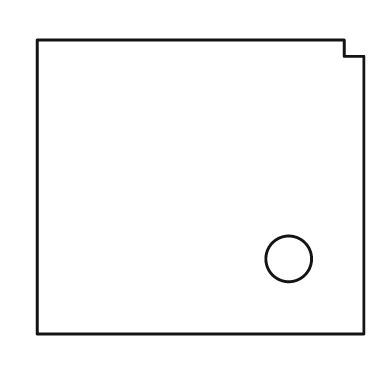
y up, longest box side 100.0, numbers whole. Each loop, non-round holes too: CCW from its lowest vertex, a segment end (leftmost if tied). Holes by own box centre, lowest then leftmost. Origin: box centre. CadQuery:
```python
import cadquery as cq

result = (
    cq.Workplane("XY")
    .moveTo(-50.0, -45.0)
    .lineTo(50.0, -45.0)
    .lineTo(50.0, 40.0)
    .lineTo(44.0, 40.0)
    .lineTo(44.0, 45.0)
    .lineTo(-50.0, 45.0)
    .close()
    .moveTo(27.0, -22.0)
    .circle(7.0)
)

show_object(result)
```